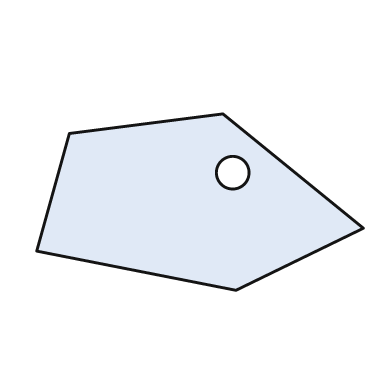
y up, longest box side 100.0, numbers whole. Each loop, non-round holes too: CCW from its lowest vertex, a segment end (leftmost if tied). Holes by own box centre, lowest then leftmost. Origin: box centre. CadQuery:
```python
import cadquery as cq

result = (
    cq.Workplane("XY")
    .moveTo(11.0, -27.0)
    .lineTo(50.0, -8.0)
    .lineTo(7.0, 27.0)
    .lineTo(-40.0, 21.0)
    .lineTo(-50.0, -15.0)
    .close()
    .moveTo(10.0, 9.0)
    .circle(5.0)
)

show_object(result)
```